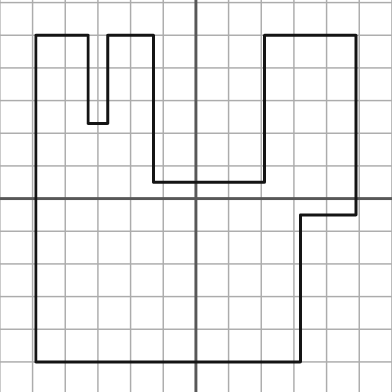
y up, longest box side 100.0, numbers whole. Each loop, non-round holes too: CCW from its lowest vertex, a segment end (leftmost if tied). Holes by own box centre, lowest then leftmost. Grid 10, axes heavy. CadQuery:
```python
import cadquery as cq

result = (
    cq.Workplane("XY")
    .moveTo(-49.0, -50.0)
    .lineTo(32.0, -50.0)
    .lineTo(32.0, -5.0)
    .lineTo(49.0, -5.0)
    .lineTo(49.0, 50.0)
    .lineTo(21.0, 50.0)
    .lineTo(21.0, 5.0)
    .lineTo(-13.0, 5.0)
    .lineTo(-13.0, 50.0)
    .lineTo(-27.0, 50.0)
    .lineTo(-27.0, 23.0)
    .lineTo(-33.0, 23.0)
    .lineTo(-33.0, 50.0)
    .lineTo(-49.0, 50.0)
    .close()
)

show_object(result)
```